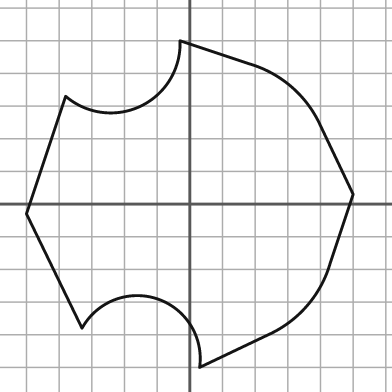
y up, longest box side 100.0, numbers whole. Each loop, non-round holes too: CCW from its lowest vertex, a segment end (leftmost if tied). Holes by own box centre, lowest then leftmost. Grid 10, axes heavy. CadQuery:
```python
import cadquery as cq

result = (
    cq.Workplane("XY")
    .moveTo(3.0, -50.0)
    .lineTo(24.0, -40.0)
    .threePointArc((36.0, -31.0), (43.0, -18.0))
    .lineTo(50.0, 3.0)
    .lineTo(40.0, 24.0)
    .threePointArc((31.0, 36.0), (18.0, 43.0))
    .lineTo(-3.0, 50.0)
    .threePointArc((-15.0, 30.0), (-38.0, 33.0))
    .lineTo(-50.0, -3.0)
    .lineTo(-33.0, -38.0)
    .threePointArc((-10.0, -29.0), (3.0, -50.0))
    .close()
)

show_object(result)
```